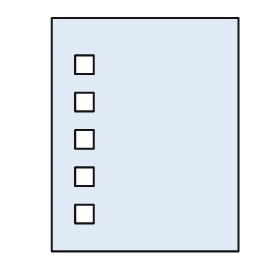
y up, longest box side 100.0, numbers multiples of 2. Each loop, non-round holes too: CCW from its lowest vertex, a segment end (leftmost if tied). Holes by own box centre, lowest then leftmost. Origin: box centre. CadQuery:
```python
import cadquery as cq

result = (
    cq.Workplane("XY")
    .moveTo(-40.0, -50.0)
    .lineTo(40.0, -50.0)
    .lineTo(40.0, 50.0)
    .lineTo(-40.0, 50.0)
    .close()
    .moveTo(-30.0, -38.0)
    .lineTo(-22.0, -38.0)
    .lineTo(-22.0, -30.0)
    .lineTo(-30.0, -30.0)
    .close()
    .moveTo(-30.0, -22.0)
    .lineTo(-22.0, -22.0)
    .lineTo(-22.0, -14.0)
    .lineTo(-30.0, -14.0)
    .close()
    .moveTo(-30.0, -6.0)
    .lineTo(-22.0, -6.0)
    .lineTo(-22.0, 2.0)
    .lineTo(-30.0, 2.0)
    .close()
    .moveTo(-30.0, 10.0)
    .lineTo(-22.0, 10.0)
    .lineTo(-22.0, 18.0)
    .lineTo(-30.0, 18.0)
    .close()
    .moveTo(-30.0, 26.0)
    .lineTo(-22.0, 26.0)
    .lineTo(-22.0, 34.0)
    .lineTo(-30.0, 34.0)
    .close()
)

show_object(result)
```